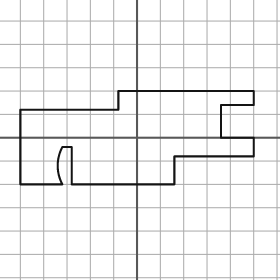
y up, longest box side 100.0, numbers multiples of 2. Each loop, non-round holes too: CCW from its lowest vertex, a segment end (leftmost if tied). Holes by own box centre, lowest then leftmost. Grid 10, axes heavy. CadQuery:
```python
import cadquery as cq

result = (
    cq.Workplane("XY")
    .moveTo(-50.0, -20.0)
    .lineTo(-32.0, -20.0)
    .threePointArc((-34.0, -12.0), (-32.0, -4.0))
    .lineTo(-28.0, -4.0)
    .lineTo(-28.0, -20.0)
    .lineTo(16.0, -20.0)
    .lineTo(16.0, -8.0)
    .lineTo(50.0, -8.0)
    .lineTo(50.0, 0.0)
    .lineTo(36.0, 0.0)
    .lineTo(36.0, 14.0)
    .lineTo(50.0, 14.0)
    .lineTo(50.0, 20.0)
    .lineTo(-8.0, 20.0)
    .lineTo(-8.0, 12.0)
    .lineTo(-50.0, 12.0)
    .close()
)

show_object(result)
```